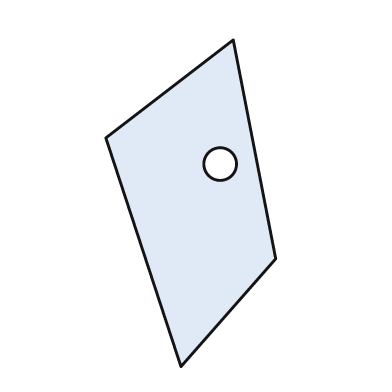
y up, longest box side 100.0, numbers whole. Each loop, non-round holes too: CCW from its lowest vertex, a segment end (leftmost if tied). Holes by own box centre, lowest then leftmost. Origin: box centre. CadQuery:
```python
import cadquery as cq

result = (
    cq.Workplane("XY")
    .moveTo(-3.0, -50.0)
    .lineTo(26.0, -17.0)
    .lineTo(13.0, 50.0)
    .lineTo(-26.0, 20.0)
    .close()
    .moveTo(9.0, 12.0)
    .circle(5.0)
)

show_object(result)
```